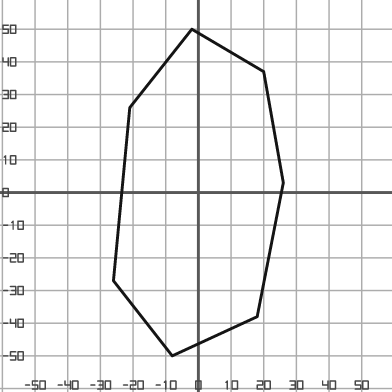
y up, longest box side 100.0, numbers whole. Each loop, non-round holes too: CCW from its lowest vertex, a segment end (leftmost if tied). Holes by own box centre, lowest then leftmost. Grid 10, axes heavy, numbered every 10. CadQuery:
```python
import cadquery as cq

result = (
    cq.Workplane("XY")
    .moveTo(-8.0, -50.0)
    .lineTo(18.0, -38.0)
    .lineTo(26.0, 3.0)
    .lineTo(20.0, 37.0)
    .lineTo(-2.0, 50.0)
    .lineTo(-21.0, 26.0)
    .lineTo(-26.0, -27.0)
    .close()
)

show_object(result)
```